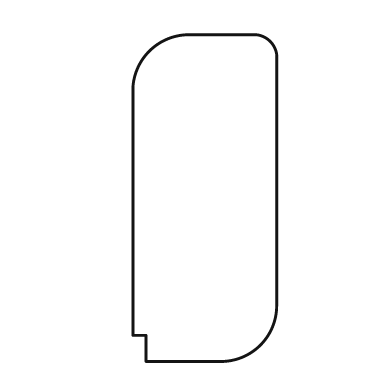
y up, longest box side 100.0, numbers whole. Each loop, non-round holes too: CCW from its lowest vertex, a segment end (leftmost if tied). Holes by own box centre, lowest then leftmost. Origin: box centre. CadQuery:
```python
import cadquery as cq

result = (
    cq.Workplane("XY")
    .moveTo(-18.0, -50.0)
    .lineTo(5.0, -50.0)
    .threePointArc((17.0, -45.0), (22.0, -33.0))
    .lineTo(22.0, 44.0)
    .threePointArc((20.0, 48.0), (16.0, 50.0))
    .lineTo(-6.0, 50.0)
    .threePointArc((-17.0, 45.0), (-22.0, 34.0))
    .lineTo(-22.0, -42.0)
    .lineTo(-18.0, -42.0)
    .close()
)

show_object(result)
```